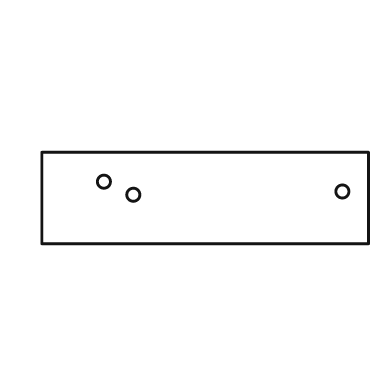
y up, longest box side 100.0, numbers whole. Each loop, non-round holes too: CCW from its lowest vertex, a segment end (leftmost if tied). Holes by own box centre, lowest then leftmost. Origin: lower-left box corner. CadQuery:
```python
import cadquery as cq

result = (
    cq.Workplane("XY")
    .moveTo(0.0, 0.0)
    .lineTo(100.0, 0.0)
    .lineTo(100.0, 28.0)
    .lineTo(0.0, 28.0)
    .close()
    .moveTo(28.0, 15.0)
    .circle(2.0)
    .moveTo(92.0, 16.0)
    .circle(2.0)
    .moveTo(19.0, 19.0)
    .circle(2.0)
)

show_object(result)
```